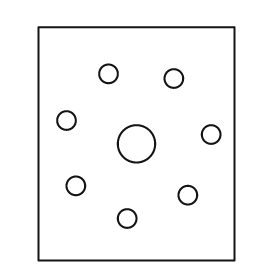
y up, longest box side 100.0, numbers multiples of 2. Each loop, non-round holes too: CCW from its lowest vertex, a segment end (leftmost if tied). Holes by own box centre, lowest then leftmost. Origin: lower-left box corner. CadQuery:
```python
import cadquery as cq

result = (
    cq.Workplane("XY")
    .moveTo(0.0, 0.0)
    .lineTo(84.0, 0.0)
    .lineTo(84.0, 100.0)
    .lineTo(0.0, 100.0)
    .close()
    .moveTo(38.0, 18.0)
    .circle(4.0)
    .moveTo(64.0, 28.0)
    .circle(4.0)
    .moveTo(16.0, 32.0)
    .circle(4.0)
    .moveTo(42.0, 50.0)
    .circle(8.0)
    .moveTo(74.0, 54.0)
    .circle(4.0)
    .moveTo(12.0, 60.0)
    .circle(4.0)
    .moveTo(58.0, 78.0)
    .circle(4.0)
    .moveTo(30.0, 80.0)
    .circle(4.0)
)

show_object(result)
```